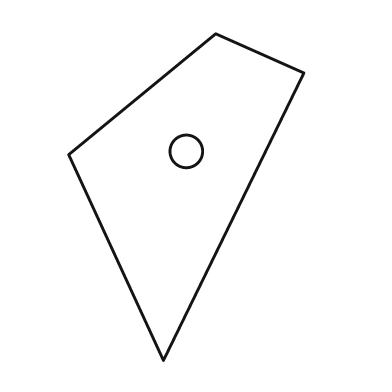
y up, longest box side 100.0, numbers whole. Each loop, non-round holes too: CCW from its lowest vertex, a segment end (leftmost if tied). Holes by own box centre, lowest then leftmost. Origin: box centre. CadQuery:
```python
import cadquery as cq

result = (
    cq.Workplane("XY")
    .moveTo(-7.0, -50.0)
    .lineTo(36.0, 38.0)
    .lineTo(9.0, 50.0)
    .lineTo(-36.0, 13.0)
    .close()
    .moveTo(0.0, 14.0)
    .circle(5.0)
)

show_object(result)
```